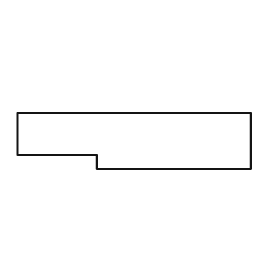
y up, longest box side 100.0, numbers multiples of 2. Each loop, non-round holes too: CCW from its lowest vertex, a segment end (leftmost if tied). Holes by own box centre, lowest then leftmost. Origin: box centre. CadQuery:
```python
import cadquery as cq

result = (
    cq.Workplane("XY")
    .moveTo(-16.0, -12.0)
    .lineTo(50.0, -12.0)
    .lineTo(50.0, 12.0)
    .lineTo(-50.0, 12.0)
    .lineTo(-50.0, -6.0)
    .lineTo(-16.0, -6.0)
    .close()
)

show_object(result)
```